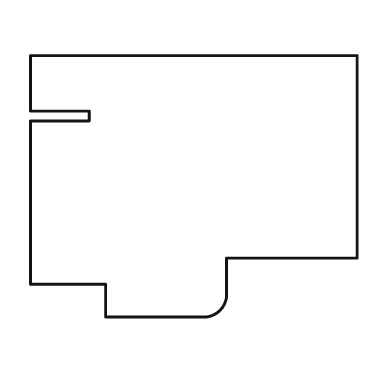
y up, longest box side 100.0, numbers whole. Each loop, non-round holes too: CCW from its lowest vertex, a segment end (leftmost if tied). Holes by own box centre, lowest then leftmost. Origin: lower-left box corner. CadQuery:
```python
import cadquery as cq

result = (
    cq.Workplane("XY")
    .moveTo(23.0, 0.0)
    .lineTo(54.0, 0.0)
    .threePointArc((58.0, 2.0), (60.0, 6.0))
    .lineTo(60.0, 18.0)
    .lineTo(100.0, 18.0)
    .lineTo(100.0, 80.0)
    .lineTo(0.0, 80.0)
    .lineTo(0.0, 63.0)
    .lineTo(18.0, 63.0)
    .lineTo(18.0, 60.0)
    .lineTo(0.0, 60.0)
    .lineTo(0.0, 10.0)
    .lineTo(23.0, 10.0)
    .close()
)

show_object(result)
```